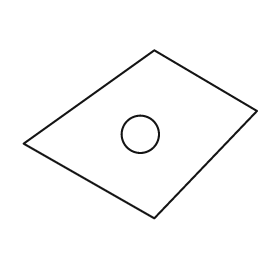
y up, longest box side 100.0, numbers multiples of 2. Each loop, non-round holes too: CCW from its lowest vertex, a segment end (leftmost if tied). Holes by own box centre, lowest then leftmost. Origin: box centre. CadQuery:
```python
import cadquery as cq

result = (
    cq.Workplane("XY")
    .moveTo(6.0, -36.0)
    .lineTo(50.0, 10.0)
    .lineTo(6.0, 36.0)
    .lineTo(-50.0, -4.0)
    .close()
    .moveTo(0.0, 0.0)
    .circle(8.0)
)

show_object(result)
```